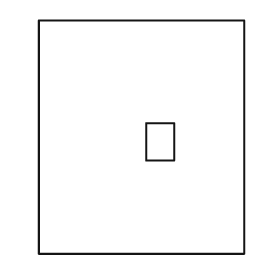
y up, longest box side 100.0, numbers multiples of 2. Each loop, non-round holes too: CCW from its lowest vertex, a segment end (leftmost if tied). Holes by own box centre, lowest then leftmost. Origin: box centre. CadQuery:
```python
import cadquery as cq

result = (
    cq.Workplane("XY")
    .moveTo(-44.0, -50.0)
    .lineTo(44.0, -50.0)
    .lineTo(44.0, 50.0)
    .lineTo(-44.0, 50.0)
    .close()
    .moveTo(2.0, -10.0)
    .lineTo(14.0, -10.0)
    .lineTo(14.0, 6.0)
    .lineTo(2.0, 6.0)
    .close()
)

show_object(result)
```